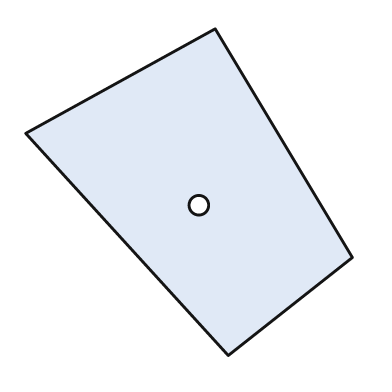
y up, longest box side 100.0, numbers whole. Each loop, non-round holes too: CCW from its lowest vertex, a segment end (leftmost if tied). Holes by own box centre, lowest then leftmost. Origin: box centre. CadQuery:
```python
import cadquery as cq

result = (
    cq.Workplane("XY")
    .moveTo(12.0, -50.0)
    .lineTo(50.0, -20.0)
    .lineTo(8.0, 50.0)
    .lineTo(-50.0, 18.0)
    .close()
    .moveTo(3.0, -4.0)
    .circle(3.0)
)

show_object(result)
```